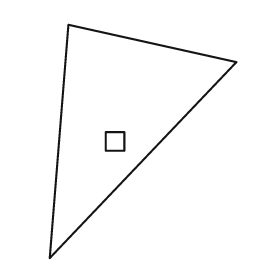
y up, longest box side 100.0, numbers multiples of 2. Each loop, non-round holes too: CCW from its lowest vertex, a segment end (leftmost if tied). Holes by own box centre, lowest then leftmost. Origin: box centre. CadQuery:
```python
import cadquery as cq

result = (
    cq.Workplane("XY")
    .moveTo(-40.0, -50.0)
    .lineTo(40.0, 34.0)
    .lineTo(-32.0, 50.0)
    .close()
    .moveTo(-16.0, -4.0)
    .lineTo(-8.0, -4.0)
    .lineTo(-8.0, 4.0)
    .lineTo(-16.0, 4.0)
    .close()
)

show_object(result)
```